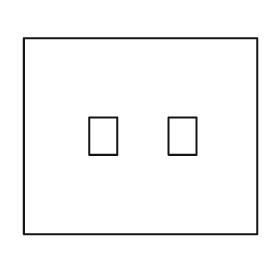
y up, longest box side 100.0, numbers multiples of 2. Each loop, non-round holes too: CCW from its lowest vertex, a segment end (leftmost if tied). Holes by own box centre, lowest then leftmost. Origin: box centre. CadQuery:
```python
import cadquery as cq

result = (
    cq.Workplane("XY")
    .moveTo(-50.0, -42.0)
    .lineTo(50.0, -42.0)
    .lineTo(50.0, 42.0)
    .lineTo(-50.0, 42.0)
    .close()
    .moveTo(-22.0, -8.0)
    .lineTo(-10.0, -8.0)
    .lineTo(-10.0, 8.0)
    .lineTo(-22.0, 8.0)
    .close()
    .moveTo(12.0, -8.0)
    .lineTo(24.0, -8.0)
    .lineTo(24.0, 8.0)
    .lineTo(12.0, 8.0)
    .close()
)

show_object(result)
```